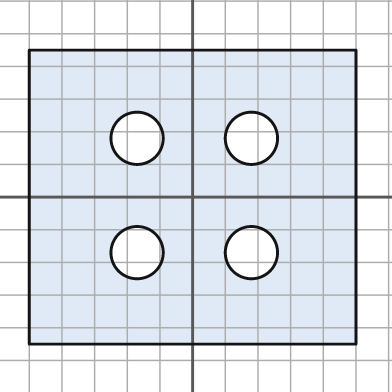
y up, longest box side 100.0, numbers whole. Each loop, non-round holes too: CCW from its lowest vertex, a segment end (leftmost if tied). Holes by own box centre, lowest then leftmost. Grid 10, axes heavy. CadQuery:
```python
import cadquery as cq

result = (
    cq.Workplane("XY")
    .moveTo(-50.0, -45.0)
    .lineTo(50.0, -45.0)
    .lineTo(50.0, 45.0)
    .lineTo(-50.0, 45.0)
    .close()
    .moveTo(-17.0, -17.0)
    .circle(8.0)
    .moveTo(18.0, -17.0)
    .circle(8.0)
    .moveTo(-17.0, 18.0)
    .circle(8.0)
    .moveTo(18.0, 18.0)
    .circle(8.0)
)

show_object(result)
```